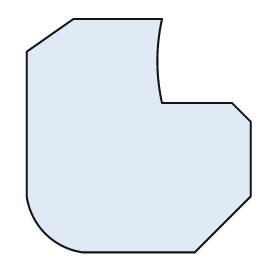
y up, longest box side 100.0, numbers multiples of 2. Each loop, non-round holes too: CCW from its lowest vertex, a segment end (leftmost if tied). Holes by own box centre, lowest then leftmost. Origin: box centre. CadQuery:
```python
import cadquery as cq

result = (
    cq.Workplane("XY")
    .moveTo(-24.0, -50.0)
    .lineTo(24.0, -50.0)
    .lineTo(48.0, -26.0)
    .lineTo(48.0, 6.0)
    .lineTo(40.0, 14.0)
    .lineTo(10.0, 14.0)
    .threePointArc((8.0, 32.0), (10.0, 50.0))
    .lineTo(-28.0, 50.0)
    .lineTo(-48.0, 36.0)
    .lineTo(-48.0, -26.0)
    .threePointArc((-40.0, -42.0), (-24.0, -50.0))
    .close()
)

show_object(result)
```